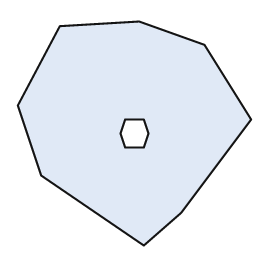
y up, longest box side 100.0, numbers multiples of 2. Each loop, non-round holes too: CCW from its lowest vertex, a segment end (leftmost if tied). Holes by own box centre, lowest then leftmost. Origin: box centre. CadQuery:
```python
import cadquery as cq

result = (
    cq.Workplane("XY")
    .moveTo(4.0, -48.0)
    .lineTo(20.0, -34.0)
    .lineTo(50.0, 6.0)
    .lineTo(30.0, 38.0)
    .lineTo(2.0, 48.0)
    .lineTo(-32.0, 46.0)
    .lineTo(-50.0, 12.0)
    .lineTo(-40.0, -18.0)
    .close()
    .moveTo(-4.0, -6.0)
    .lineTo(4.0, -6.0)
    .lineTo(6.0, 0.0)
    .lineTo(4.0, 6.0)
    .lineTo(-4.0, 6.0)
    .lineTo(-6.0, 0.0)
    .close()
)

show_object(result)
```